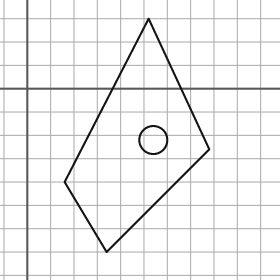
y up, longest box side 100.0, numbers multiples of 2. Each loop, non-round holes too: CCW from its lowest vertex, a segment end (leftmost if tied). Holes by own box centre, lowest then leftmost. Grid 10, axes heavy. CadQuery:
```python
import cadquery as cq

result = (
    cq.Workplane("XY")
    .moveTo(34.0, -70.0)
    .lineTo(78.0, -26.0)
    .lineTo(52.0, 30.0)
    .lineTo(16.0, -40.0)
    .close()
    .moveTo(54.0, -22.0)
    .circle(6.0)
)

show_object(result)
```